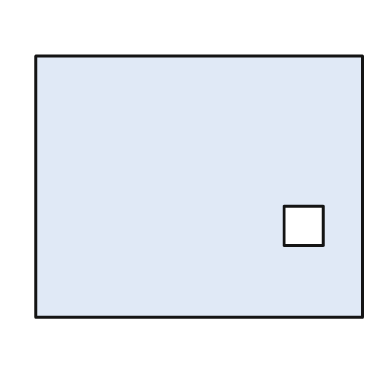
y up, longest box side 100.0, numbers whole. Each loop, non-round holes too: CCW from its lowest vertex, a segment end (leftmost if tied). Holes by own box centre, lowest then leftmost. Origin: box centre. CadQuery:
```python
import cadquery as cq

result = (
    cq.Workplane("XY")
    .moveTo(-50.0, -40.0)
    .lineTo(50.0, -40.0)
    .lineTo(50.0, 40.0)
    .lineTo(-50.0, 40.0)
    .close()
    .moveTo(26.0, -18.0)
    .lineTo(38.0, -18.0)
    .lineTo(38.0, -6.0)
    .lineTo(26.0, -6.0)
    .close()
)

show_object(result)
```